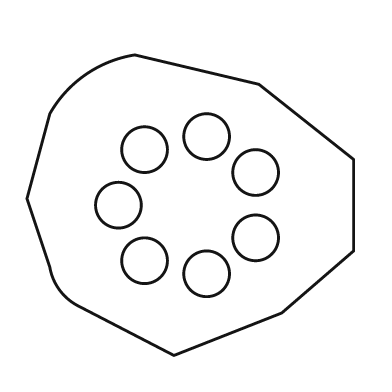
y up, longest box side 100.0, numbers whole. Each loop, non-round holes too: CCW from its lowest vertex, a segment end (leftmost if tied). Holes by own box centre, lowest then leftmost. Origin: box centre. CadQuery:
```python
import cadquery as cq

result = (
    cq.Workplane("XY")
    .moveTo(-5.0, -46.0)
    .lineTo(28.0, -33.0)
    .lineTo(50.0, -14.0)
    .lineTo(50.0, 14.0)
    .lineTo(21.0, 37.0)
    .lineTo(-17.0, 46.0)
    .threePointArc((-32.0, 40.0), (-43.0, 28.0))
    .lineTo(-50.0, 2.0)
    .lineTo(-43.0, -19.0)
    .threePointArc((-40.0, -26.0), (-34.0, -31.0))
    .close()
    .moveTo(5.0, -21.0)
    .circle(7.0)
    .moveTo(-14.0, -17.0)
    .circle(7.0)
    .moveTo(20.0, -10.0)
    .circle(7.0)
    .moveTo(-22.0, 0.0)
    .circle(7.0)
    .moveTo(20.0, 10.0)
    .circle(7.0)
    .moveTo(-14.0, 17.0)
    .circle(7.0)
    .moveTo(5.0, 21.0)
    .circle(7.0)
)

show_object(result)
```